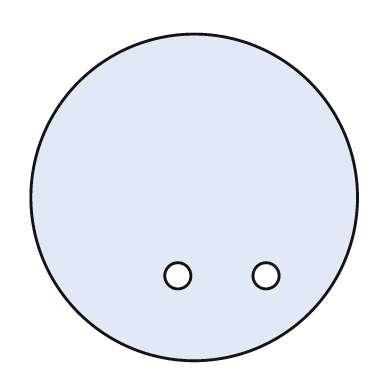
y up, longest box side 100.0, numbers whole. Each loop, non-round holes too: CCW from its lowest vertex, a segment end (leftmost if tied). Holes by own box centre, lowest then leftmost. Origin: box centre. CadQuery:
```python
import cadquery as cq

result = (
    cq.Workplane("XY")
    .moveTo(0.0, 0.0)
    .circle(50.0)
    .moveTo(-5.0, -24.0)
    .circle(4.0)
    .moveTo(22.0, -24.0)
    .circle(4.0)
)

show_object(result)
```